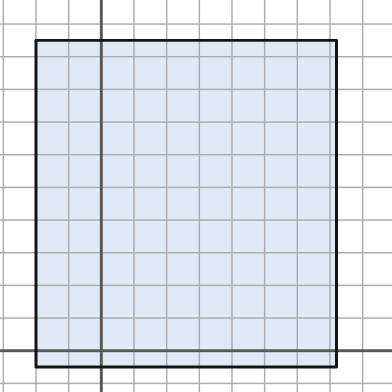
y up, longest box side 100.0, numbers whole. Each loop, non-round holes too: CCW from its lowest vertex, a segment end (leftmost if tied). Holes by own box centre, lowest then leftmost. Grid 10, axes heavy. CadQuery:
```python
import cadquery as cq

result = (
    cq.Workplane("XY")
    .moveTo(-20.0, -5.0)
    .lineTo(72.0, -5.0)
    .lineTo(72.0, 95.0)
    .lineTo(-20.0, 95.0)
    .close()
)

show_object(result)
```